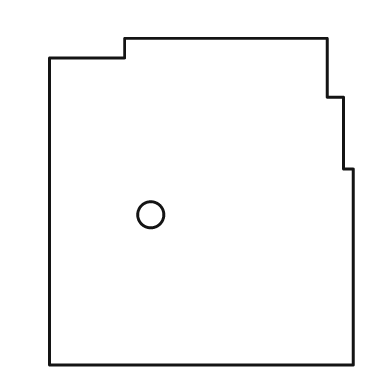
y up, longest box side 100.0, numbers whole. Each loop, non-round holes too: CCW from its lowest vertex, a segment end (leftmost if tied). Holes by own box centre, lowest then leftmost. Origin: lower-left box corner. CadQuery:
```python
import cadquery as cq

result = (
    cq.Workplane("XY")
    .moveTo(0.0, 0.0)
    .lineTo(93.0, 0.0)
    .lineTo(93.0, 60.0)
    .lineTo(90.0, 60.0)
    .lineTo(90.0, 82.0)
    .lineTo(85.0, 82.0)
    .lineTo(85.0, 100.0)
    .lineTo(23.0, 100.0)
    .lineTo(23.0, 94.0)
    .lineTo(0.0, 94.0)
    .close()
    .moveTo(31.0, 46.0)
    .circle(4.0)
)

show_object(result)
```